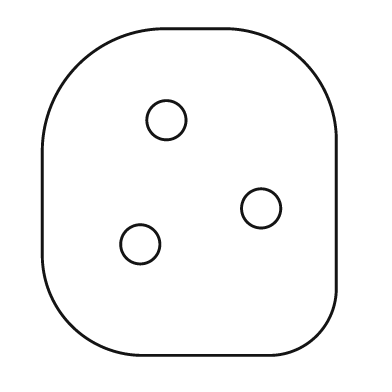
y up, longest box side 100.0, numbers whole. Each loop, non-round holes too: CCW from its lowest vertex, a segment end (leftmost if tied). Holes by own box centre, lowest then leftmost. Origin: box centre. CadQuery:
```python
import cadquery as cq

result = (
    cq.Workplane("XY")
    .moveTo(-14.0, -50.0)
    .lineTo(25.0, -50.0)
    .threePointArc((39.0, -44.0), (45.0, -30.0))
    .lineTo(45.0, 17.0)
    .threePointArc((35.0, 40.0), (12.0, 50.0))
    .lineTo(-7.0, 50.0)
    .threePointArc((-34.0, 39.0), (-45.0, 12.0))
    .lineTo(-45.0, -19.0)
    .threePointArc((-36.0, -41.0), (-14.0, -50.0))
    .close()
    .moveTo(-15.0, -16.0)
    .circle(6.0)
    .moveTo(22.0, -5.0)
    .circle(6.0)
    .moveTo(-7.0, 22.0)
    .circle(6.0)
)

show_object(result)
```